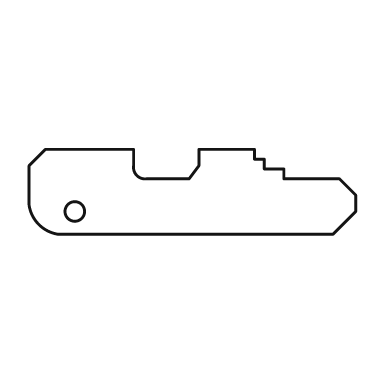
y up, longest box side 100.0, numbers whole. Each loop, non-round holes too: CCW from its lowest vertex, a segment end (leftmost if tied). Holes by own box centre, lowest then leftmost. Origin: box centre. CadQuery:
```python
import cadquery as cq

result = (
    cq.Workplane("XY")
    .moveTo(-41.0, -13.0)
    .lineTo(43.0, -13.0)
    .lineTo(50.0, -6.0)
    .lineTo(50.0, -1.0)
    .lineTo(45.0, 4.0)
    .lineTo(28.0, 4.0)
    .lineTo(28.0, 7.0)
    .lineTo(22.0, 7.0)
    .lineTo(22.0, 10.0)
    .lineTo(19.0, 10.0)
    .lineTo(19.0, 13.0)
    .lineTo(2.0, 13.0)
    .lineTo(2.0, 8.0)
    .lineTo(-1.0, 4.0)
    .lineTo(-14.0, 4.0)
    .threePointArc((-17.0, 5.0), (-18.0, 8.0))
    .lineTo(-18.0, 13.0)
    .lineTo(-45.0, 13.0)
    .lineTo(-50.0, 8.0)
    .lineTo(-50.0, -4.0)
    .threePointArc((-47.0, -10.0), (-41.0, -13.0))
    .close()
    .moveTo(-36.0, -6.0)
    .circle(3.0)
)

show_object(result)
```